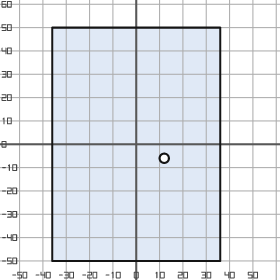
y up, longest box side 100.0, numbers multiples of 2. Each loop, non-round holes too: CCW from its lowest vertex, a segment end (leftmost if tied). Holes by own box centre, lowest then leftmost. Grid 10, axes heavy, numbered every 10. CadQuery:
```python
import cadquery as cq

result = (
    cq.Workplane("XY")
    .moveTo(-36.0, -50.0)
    .lineTo(36.0, -50.0)
    .lineTo(36.0, 50.0)
    .lineTo(-36.0, 50.0)
    .close()
    .moveTo(12.0, -6.0)
    .circle(2.0)
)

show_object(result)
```